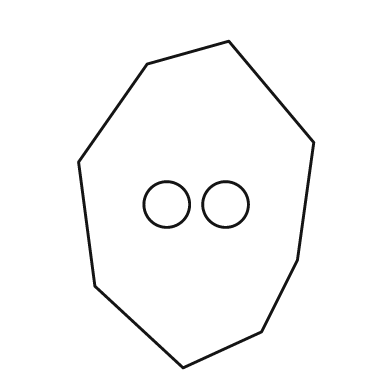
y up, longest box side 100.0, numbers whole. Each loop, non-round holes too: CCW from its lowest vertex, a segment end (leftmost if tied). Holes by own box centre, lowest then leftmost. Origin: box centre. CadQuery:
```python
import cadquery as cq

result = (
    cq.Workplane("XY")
    .moveTo(-4.0, -50.0)
    .lineTo(20.0, -39.0)
    .lineTo(31.0, -17.0)
    .lineTo(36.0, 19.0)
    .lineTo(10.0, 50.0)
    .lineTo(-15.0, 43.0)
    .lineTo(-36.0, 13.0)
    .lineTo(-31.0, -25.0)
    .close()
    .moveTo(-9.0, 0.0)
    .circle(7.0)
    .moveTo(9.0, 0.0)
    .circle(7.0)
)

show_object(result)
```